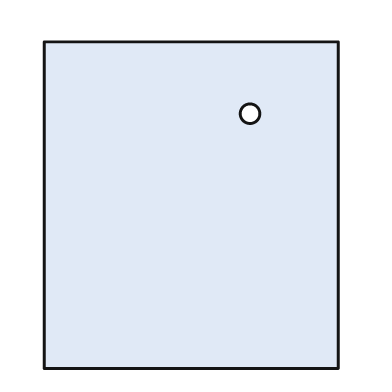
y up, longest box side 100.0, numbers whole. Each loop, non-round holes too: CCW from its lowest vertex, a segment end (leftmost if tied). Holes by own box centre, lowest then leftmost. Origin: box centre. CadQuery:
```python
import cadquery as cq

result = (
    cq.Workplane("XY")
    .moveTo(-45.0, -50.0)
    .lineTo(45.0, -50.0)
    .lineTo(45.0, 50.0)
    .lineTo(-45.0, 50.0)
    .close()
    .moveTo(18.0, 28.0)
    .circle(3.0)
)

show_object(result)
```